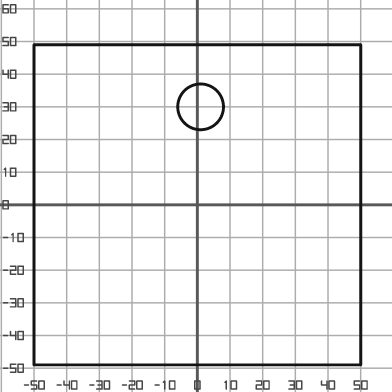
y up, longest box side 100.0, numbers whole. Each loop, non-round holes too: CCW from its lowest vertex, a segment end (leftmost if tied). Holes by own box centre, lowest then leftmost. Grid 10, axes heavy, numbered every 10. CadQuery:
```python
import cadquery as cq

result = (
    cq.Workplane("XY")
    .moveTo(-50.0, -49.0)
    .lineTo(50.0, -49.0)
    .lineTo(50.0, 49.0)
    .lineTo(-50.0, 49.0)
    .close()
    .moveTo(1.0, 30.0)
    .circle(7.0)
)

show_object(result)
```